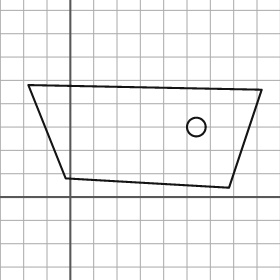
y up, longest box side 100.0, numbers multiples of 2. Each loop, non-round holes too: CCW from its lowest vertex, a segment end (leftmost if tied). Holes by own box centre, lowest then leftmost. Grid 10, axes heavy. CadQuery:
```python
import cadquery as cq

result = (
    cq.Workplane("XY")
    .moveTo(68.0, 4.0)
    .lineTo(82.0, 46.0)
    .lineTo(-18.0, 48.0)
    .lineTo(-2.0, 8.0)
    .close()
    .moveTo(54.0, 30.0)
    .circle(4.0)
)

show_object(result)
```